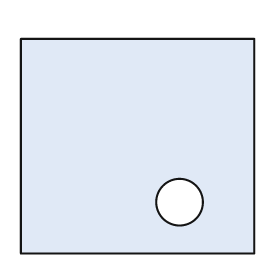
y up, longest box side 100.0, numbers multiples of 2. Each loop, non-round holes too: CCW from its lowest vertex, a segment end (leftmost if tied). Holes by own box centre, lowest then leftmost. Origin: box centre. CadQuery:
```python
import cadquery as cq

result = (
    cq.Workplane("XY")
    .moveTo(-50.0, -46.0)
    .lineTo(50.0, -46.0)
    .lineTo(50.0, 46.0)
    .lineTo(-50.0, 46.0)
    .close()
    .moveTo(18.0, -24.0)
    .circle(10.0)
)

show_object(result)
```